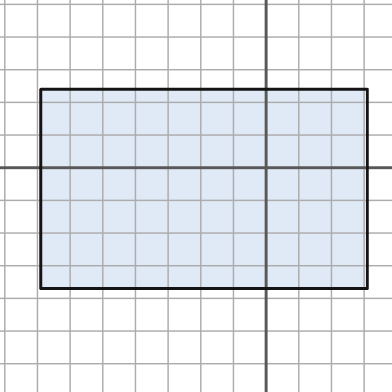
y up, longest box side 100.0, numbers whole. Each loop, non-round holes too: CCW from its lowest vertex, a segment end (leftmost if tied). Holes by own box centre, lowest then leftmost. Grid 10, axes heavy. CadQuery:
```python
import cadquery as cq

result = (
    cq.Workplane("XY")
    .moveTo(-69.0, -37.0)
    .lineTo(31.0, -37.0)
    .lineTo(31.0, 24.0)
    .lineTo(-69.0, 24.0)
    .close()
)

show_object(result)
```